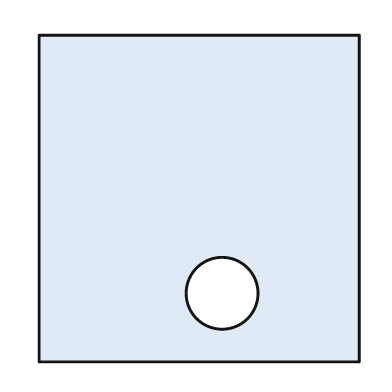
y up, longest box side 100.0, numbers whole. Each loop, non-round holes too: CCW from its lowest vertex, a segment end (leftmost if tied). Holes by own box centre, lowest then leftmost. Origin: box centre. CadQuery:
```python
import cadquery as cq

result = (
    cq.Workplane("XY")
    .moveTo(-49.0, -50.0)
    .lineTo(49.0, -50.0)
    .lineTo(49.0, 50.0)
    .lineTo(-49.0, 50.0)
    .close()
    .moveTo(7.0, -29.0)
    .circle(11.0)
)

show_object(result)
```